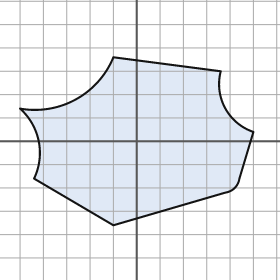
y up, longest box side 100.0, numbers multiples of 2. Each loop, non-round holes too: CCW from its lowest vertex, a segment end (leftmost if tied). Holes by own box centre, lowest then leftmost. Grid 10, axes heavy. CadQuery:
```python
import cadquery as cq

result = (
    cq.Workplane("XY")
    .moveTo(-10.0, -36.0)
    .lineTo(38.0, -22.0)
    .threePointArc((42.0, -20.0), (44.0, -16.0))
    .lineTo(50.0, 4.0)
    .threePointArc((38.0, 14.0), (36.0, 30.0))
    .lineTo(-10.0, 36.0)
    .threePointArc((-26.0, 18.0), (-50.0, 14.0))
    .threePointArc((-42.0, 0.0), (-44.0, -16.0))
    .close()
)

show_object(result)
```